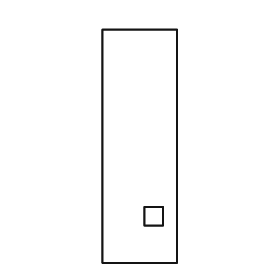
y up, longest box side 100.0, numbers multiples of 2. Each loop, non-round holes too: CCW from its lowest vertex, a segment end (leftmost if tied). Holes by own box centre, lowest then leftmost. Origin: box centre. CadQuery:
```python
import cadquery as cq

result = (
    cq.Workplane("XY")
    .moveTo(-16.0, -50.0)
    .lineTo(16.0, -50.0)
    .lineTo(16.0, 50.0)
    .lineTo(-16.0, 50.0)
    .close()
    .moveTo(2.0, -34.0)
    .lineTo(10.0, -34.0)
    .lineTo(10.0, -26.0)
    .lineTo(2.0, -26.0)
    .close()
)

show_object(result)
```